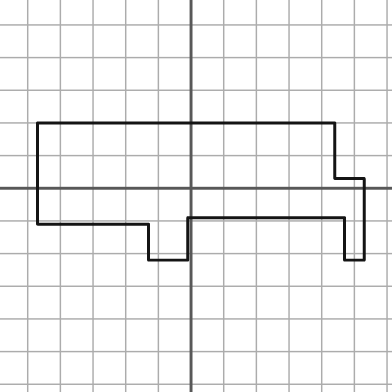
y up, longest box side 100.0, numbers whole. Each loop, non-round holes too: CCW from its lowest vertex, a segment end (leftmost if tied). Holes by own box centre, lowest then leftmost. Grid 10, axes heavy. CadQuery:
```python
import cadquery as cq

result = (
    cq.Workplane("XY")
    .moveTo(-13.0, -22.0)
    .lineTo(-1.0, -22.0)
    .lineTo(-1.0, -9.0)
    .lineTo(47.0, -9.0)
    .lineTo(47.0, -22.0)
    .lineTo(53.0, -22.0)
    .lineTo(53.0, 3.0)
    .lineTo(44.0, 3.0)
    .lineTo(44.0, 20.0)
    .lineTo(-47.0, 20.0)
    .lineTo(-47.0, -11.0)
    .lineTo(-13.0, -11.0)
    .close()
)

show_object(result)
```